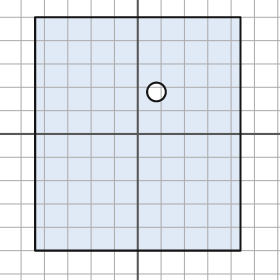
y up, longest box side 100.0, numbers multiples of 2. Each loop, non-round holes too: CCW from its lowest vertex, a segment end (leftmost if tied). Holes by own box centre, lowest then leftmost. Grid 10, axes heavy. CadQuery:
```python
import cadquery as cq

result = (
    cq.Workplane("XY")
    .moveTo(-44.0, -50.0)
    .lineTo(44.0, -50.0)
    .lineTo(44.0, 50.0)
    .lineTo(-44.0, 50.0)
    .close()
    .moveTo(8.0, 18.0)
    .circle(4.0)
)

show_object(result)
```